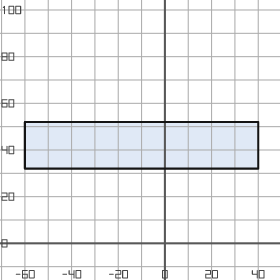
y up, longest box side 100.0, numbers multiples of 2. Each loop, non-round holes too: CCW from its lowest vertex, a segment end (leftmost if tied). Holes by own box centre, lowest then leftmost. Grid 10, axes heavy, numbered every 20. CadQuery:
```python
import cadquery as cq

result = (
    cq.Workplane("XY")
    .moveTo(-60.0, 32.0)
    .lineTo(40.0, 32.0)
    .lineTo(40.0, 52.0)
    .lineTo(-60.0, 52.0)
    .close()
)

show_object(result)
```